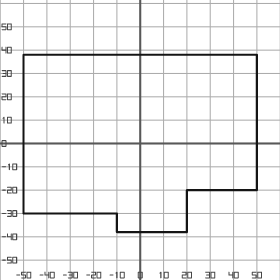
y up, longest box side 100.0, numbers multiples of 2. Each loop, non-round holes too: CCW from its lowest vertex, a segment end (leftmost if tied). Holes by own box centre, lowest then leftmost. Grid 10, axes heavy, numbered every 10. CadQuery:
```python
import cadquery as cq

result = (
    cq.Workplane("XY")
    .moveTo(-10.0, -38.0)
    .lineTo(20.0, -38.0)
    .lineTo(20.0, -20.0)
    .lineTo(50.0, -20.0)
    .lineTo(50.0, 38.0)
    .lineTo(-50.0, 38.0)
    .lineTo(-50.0, -30.0)
    .lineTo(-10.0, -30.0)
    .close()
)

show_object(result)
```